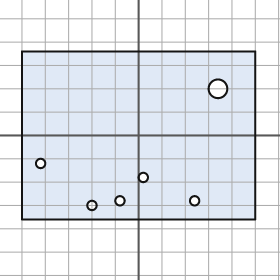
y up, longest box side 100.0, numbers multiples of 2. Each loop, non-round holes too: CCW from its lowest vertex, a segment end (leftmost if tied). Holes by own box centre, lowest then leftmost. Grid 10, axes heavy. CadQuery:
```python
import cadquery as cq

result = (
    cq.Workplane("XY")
    .moveTo(-50.0, -36.0)
    .lineTo(50.0, -36.0)
    .lineTo(50.0, 36.0)
    .lineTo(-50.0, 36.0)
    .close()
    .moveTo(-20.0, -30.0)
    .circle(2.0)
    .moveTo(-8.0, -28.0)
    .circle(2.0)
    .moveTo(24.0, -28.0)
    .circle(2.0)
    .moveTo(2.0, -18.0)
    .circle(2.0)
    .moveTo(-42.0, -12.0)
    .circle(2.0)
    .moveTo(34.0, 20.0)
    .circle(4.0)
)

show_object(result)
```